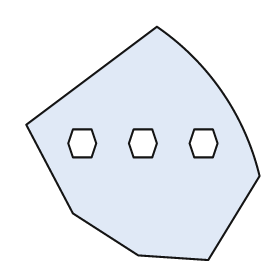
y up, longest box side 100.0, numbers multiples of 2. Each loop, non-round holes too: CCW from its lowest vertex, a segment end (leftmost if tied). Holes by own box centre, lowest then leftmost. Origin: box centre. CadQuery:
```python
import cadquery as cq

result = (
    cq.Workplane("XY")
    .moveTo(28.0, -50.0)
    .lineTo(50.0, -14.0)
    .threePointArc((34.0, 22.0), (6.0, 50.0))
    .lineTo(-50.0, 8.0)
    .lineTo(-30.0, -30.0)
    .lineTo(-2.0, -48.0)
    .close()
    .moveTo(-30.0, -6.0)
    .lineTo(-22.0, -6.0)
    .lineTo(-20.0, 0.0)
    .lineTo(-22.0, 6.0)
    .lineTo(-30.0, 6.0)
    .lineTo(-32.0, 0.0)
    .close()
    .moveTo(-4.0, -6.0)
    .lineTo(4.0, -6.0)
    .lineTo(6.0, 0.0)
    .lineTo(4.0, 6.0)
    .lineTo(-4.0, 6.0)
    .lineTo(-6.0, 0.0)
    .close()
    .moveTo(22.0, -6.0)
    .lineTo(30.0, -6.0)
    .lineTo(32.0, 0.0)
    .lineTo(30.0, 6.0)
    .lineTo(22.0, 6.0)
    .lineTo(20.0, 0.0)
    .close()
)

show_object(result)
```